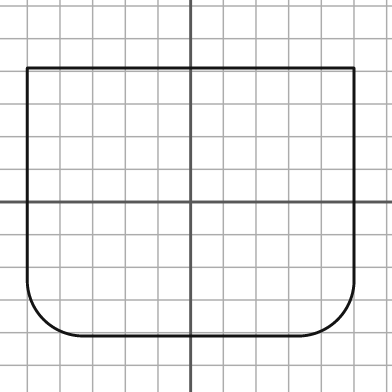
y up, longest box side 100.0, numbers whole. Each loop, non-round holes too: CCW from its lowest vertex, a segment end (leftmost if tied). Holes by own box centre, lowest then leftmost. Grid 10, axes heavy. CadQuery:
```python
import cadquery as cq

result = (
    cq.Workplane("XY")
    .moveTo(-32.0, -41.0)
    .lineTo(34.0, -41.0)
    .threePointArc((45.0, -36.0), (50.0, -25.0))
    .lineTo(50.0, 41.0)
    .lineTo(-50.0, 41.0)
    .lineTo(-50.0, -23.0)
    .threePointArc((-45.0, -36.0), (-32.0, -41.0))
    .close()
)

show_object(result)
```